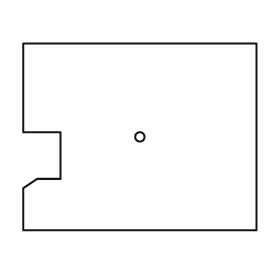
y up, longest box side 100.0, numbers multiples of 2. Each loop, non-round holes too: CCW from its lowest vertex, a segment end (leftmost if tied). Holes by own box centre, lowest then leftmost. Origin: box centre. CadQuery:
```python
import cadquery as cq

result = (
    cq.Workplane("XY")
    .moveTo(-50.0, -40.0)
    .lineTo(50.0, -40.0)
    .lineTo(50.0, 40.0)
    .lineTo(-50.0, 40.0)
    .lineTo(-50.0, 2.0)
    .lineTo(-34.0, 2.0)
    .lineTo(-34.0, -18.0)
    .lineTo(-44.0, -18.0)
    .lineTo(-50.0, -22.0)
    .close()
    .moveTo(0.0, 0.0)
    .circle(2.0)
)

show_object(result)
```